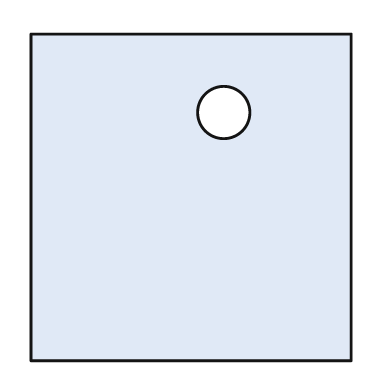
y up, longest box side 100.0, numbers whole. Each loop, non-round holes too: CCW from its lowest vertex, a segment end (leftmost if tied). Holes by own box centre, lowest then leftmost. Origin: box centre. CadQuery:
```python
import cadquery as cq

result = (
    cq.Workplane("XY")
    .moveTo(-49.0, -50.0)
    .lineTo(49.0, -50.0)
    .lineTo(49.0, 50.0)
    .lineTo(-49.0, 50.0)
    .close()
    .moveTo(10.0, 26.0)
    .circle(8.0)
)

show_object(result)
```